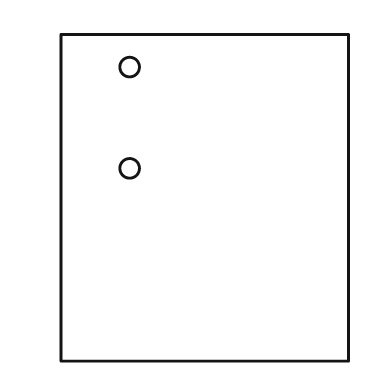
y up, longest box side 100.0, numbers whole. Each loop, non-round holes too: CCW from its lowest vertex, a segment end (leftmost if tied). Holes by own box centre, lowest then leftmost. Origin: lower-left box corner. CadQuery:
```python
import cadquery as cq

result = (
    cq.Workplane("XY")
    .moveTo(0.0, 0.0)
    .lineTo(88.0, 0.0)
    .lineTo(88.0, 100.0)
    .lineTo(0.0, 100.0)
    .close()
    .moveTo(21.0, 59.0)
    .circle(3.0)
    .moveTo(21.0, 90.0)
    .circle(3.0)
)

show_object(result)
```